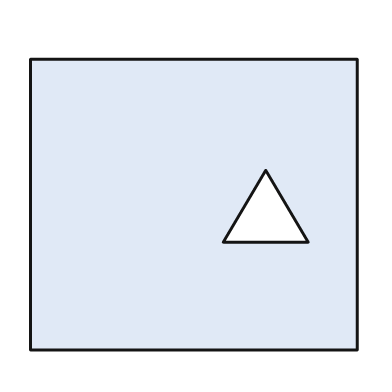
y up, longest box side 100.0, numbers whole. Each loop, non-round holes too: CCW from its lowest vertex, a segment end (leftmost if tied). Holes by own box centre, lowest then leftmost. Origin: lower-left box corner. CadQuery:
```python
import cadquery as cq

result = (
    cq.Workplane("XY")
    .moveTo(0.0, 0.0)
    .lineTo(100.0, 0.0)
    .lineTo(100.0, 89.0)
    .lineTo(0.0, 89.0)
    .close()
    .moveTo(59.0, 33.0)
    .lineTo(85.0, 33.0)
    .lineTo(72.0, 55.0)
    .close()
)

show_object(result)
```